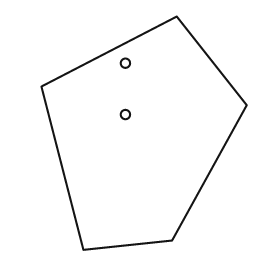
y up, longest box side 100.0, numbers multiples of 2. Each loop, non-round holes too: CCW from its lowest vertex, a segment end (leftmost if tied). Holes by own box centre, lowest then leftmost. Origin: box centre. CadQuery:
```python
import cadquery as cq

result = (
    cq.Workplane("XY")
    .moveTo(-26.0, -50.0)
    .lineTo(12.0, -46.0)
    .lineTo(44.0, 12.0)
    .lineTo(14.0, 50.0)
    .lineTo(-44.0, 20.0)
    .close()
    .moveTo(-8.0, 8.0)
    .circle(2.0)
    .moveTo(-8.0, 30.0)
    .circle(2.0)
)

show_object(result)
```